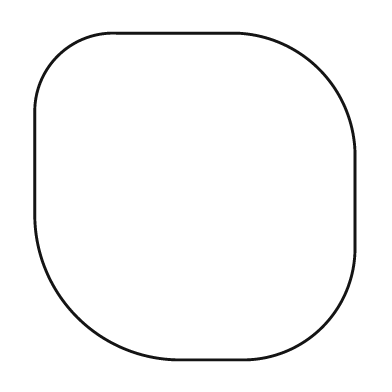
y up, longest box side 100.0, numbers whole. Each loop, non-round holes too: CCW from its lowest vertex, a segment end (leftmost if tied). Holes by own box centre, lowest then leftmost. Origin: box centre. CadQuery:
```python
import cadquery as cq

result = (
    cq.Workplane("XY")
    .moveTo(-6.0, -50.0)
    .lineTo(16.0, -50.0)
    .threePointArc((39.0, -40.0), (49.0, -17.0))
    .lineTo(49.0, 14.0)
    .threePointArc((38.0, 39.0), (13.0, 50.0))
    .lineTo(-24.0, 50.0)
    .threePointArc((-42.0, 43.0), (-49.0, 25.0))
    .lineTo(-49.0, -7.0)
    .threePointArc((-36.0, -37.0), (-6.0, -50.0))
    .close()
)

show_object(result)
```